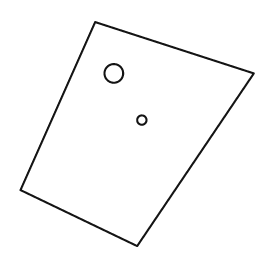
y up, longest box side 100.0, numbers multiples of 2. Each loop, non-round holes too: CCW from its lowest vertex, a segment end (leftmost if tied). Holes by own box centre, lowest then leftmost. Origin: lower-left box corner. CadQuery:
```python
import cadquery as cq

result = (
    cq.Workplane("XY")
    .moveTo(50.0, 0.0)
    .lineTo(100.0, 74.0)
    .lineTo(32.0, 96.0)
    .lineTo(0.0, 24.0)
    .close()
    .moveTo(52.0, 54.0)
    .circle(2.0)
    .moveTo(40.0, 74.0)
    .circle(4.0)
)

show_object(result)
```